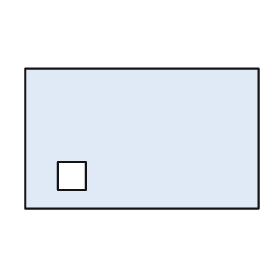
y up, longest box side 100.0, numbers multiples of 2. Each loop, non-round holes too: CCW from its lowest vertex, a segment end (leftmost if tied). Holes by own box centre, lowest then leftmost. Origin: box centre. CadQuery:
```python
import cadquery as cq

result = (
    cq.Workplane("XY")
    .moveTo(-50.0, -30.0)
    .lineTo(50.0, -30.0)
    .lineTo(50.0, 30.0)
    .lineTo(-50.0, 30.0)
    .close()
    .moveTo(-36.0, -22.0)
    .lineTo(-24.0, -22.0)
    .lineTo(-24.0, -10.0)
    .lineTo(-36.0, -10.0)
    .close()
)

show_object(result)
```